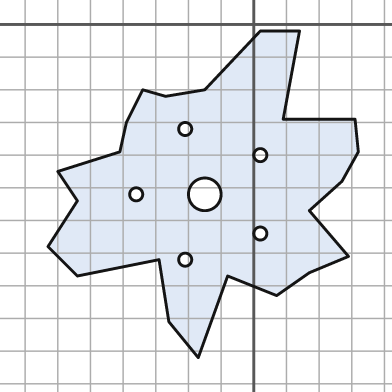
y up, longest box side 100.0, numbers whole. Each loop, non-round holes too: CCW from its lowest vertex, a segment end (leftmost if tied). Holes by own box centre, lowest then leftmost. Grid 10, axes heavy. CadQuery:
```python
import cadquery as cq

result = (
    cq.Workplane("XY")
    .moveTo(-17.0, -102.0)
    .lineTo(-8.0, -77.0)
    .lineTo(7.0, -83.0)
    .lineTo(17.0, -76.0)
    .lineTo(29.0, -71.0)
    .lineTo(17.0, -57.0)
    .lineTo(27.0, -48.0)
    .lineTo(32.0, -39.0)
    .lineTo(31.0, -29.0)
    .lineTo(9.0, -29.0)
    .lineTo(14.0, -2.0)
    .lineTo(2.0, -2.0)
    .lineTo(-15.0, -20.0)
    .lineTo(-27.0, -22.0)
    .lineTo(-34.0, -20.0)
    .lineTo(-39.0, -30.0)
    .lineTo(-41.0, -39.0)
    .lineTo(-60.0, -45.0)
    .lineTo(-54.0, -54.0)
    .lineTo(-63.0, -68.0)
    .lineTo(-54.0, -77.0)
    .lineTo(-29.0, -72.0)
    .lineTo(-26.0, -91.0)
    .close()
    .moveTo(-21.0, -72.0)
    .circle(2.0)
    .moveTo(2.0, -64.0)
    .circle(2.0)
    .moveTo(-36.0, -52.0)
    .circle(2.0)
    .moveTo(-15.0, -52.0)
    .circle(5.0)
    .moveTo(2.0, -40.0)
    .circle(2.0)
    .moveTo(-21.0, -32.0)
    .circle(2.0)
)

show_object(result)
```